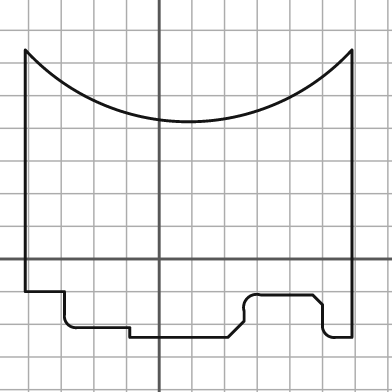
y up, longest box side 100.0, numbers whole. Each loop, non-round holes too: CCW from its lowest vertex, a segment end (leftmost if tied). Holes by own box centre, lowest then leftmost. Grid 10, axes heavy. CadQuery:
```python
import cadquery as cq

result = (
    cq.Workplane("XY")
    .moveTo(-9.0, -24.0)
    .lineTo(21.0, -24.0)
    .lineTo(26.0, -19.0)
    .lineTo(26.0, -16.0)
    .threePointArc((27.0, -12.0), (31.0, -11.0))
    .lineTo(47.0, -11.0)
    .lineTo(50.0, -14.0)
    .lineTo(50.0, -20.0)
    .threePointArc((51.0, -23.0), (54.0, -24.0))
    .lineTo(59.0, -24.0)
    .lineTo(59.0, 64.0)
    .threePointArc((9.0, 42.0), (-41.0, 64.0))
    .lineTo(-41.0, -10.0)
    .lineTo(-29.0, -10.0)
    .lineTo(-29.0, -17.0)
    .threePointArc((-28.0, -20.0), (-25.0, -21.0))
    .lineTo(-9.0, -21.0)
    .close()
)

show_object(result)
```